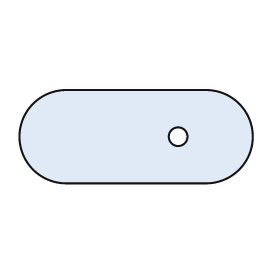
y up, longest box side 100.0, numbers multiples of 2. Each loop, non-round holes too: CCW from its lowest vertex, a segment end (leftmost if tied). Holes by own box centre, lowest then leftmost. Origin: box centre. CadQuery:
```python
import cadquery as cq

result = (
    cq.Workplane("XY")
    .moveTo(-30.0, -20.0)
    .lineTo(30.0, -20.0)
    .threePointArc((50.0, 0.0), (30.0, 20.0))
    .lineTo(-30.0, 20.0)
    .threePointArc((-50.0, 0.0), (-30.0, -20.0))
    .close()
    .moveTo(18.0, 0.0)
    .circle(4.0)
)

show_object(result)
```